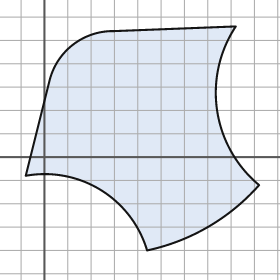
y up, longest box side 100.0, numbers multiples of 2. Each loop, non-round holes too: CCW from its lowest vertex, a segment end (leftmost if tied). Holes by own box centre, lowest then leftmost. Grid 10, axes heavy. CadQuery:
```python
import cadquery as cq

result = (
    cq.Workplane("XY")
    .moveTo(44.0, -40.0)
    .threePointArc((70.0, -30.0), (92.0, -12.0))
    .threePointArc((74.0, 20.0), (82.0, 56.0))
    .lineTo(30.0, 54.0)
    .threePointArc((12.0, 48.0), (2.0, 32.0))
    .lineTo(-8.0, -8.0)
    .threePointArc((24.0, -14.0), (44.0, -40.0))
    .close()
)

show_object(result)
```